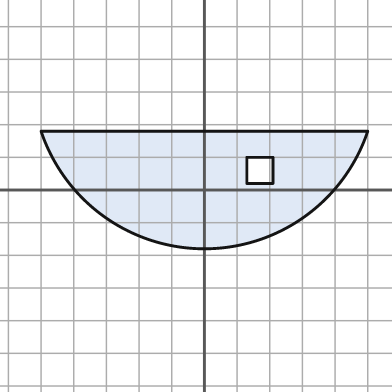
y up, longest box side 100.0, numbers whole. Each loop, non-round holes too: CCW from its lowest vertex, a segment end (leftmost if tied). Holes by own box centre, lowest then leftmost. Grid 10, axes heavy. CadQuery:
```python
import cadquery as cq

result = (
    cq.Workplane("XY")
    .moveTo(-50.0, 18.0)
    .threePointArc((0.0, -18.0), (50.0, 18.0))
    .close()
    .moveTo(13.0, 2.0)
    .lineTo(21.0, 2.0)
    .lineTo(21.0, 10.0)
    .lineTo(13.0, 10.0)
    .close()
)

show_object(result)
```